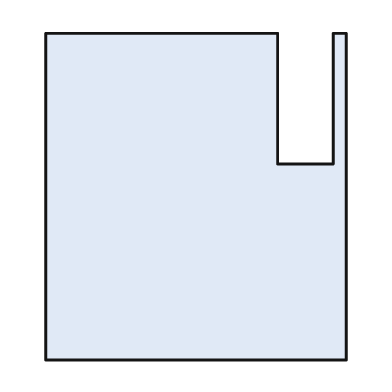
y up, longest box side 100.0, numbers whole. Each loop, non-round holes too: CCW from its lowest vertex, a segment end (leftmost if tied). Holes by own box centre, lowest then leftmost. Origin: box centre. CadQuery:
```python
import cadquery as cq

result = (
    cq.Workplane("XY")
    .moveTo(-46.0, -50.0)
    .lineTo(46.0, -50.0)
    .lineTo(46.0, 50.0)
    .lineTo(42.0, 50.0)
    .lineTo(42.0, 10.0)
    .lineTo(25.0, 10.0)
    .lineTo(25.0, 50.0)
    .lineTo(-46.0, 50.0)
    .close()
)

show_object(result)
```